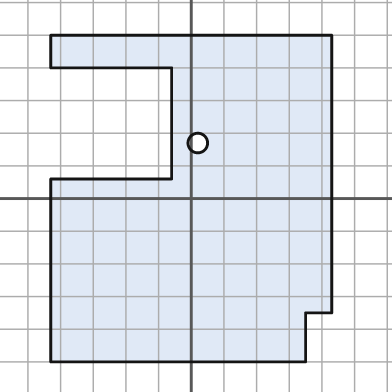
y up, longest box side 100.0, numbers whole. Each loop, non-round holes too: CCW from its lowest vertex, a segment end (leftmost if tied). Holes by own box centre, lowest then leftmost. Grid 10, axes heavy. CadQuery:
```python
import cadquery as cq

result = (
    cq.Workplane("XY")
    .moveTo(-43.0, -50.0)
    .lineTo(35.0, -50.0)
    .lineTo(35.0, -35.0)
    .lineTo(43.0, -35.0)
    .lineTo(43.0, 50.0)
    .lineTo(-43.0, 50.0)
    .lineTo(-43.0, 40.0)
    .lineTo(-6.0, 40.0)
    .lineTo(-6.0, 6.0)
    .lineTo(-43.0, 6.0)
    .close()
    .moveTo(2.0, 17.0)
    .circle(3.0)
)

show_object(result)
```